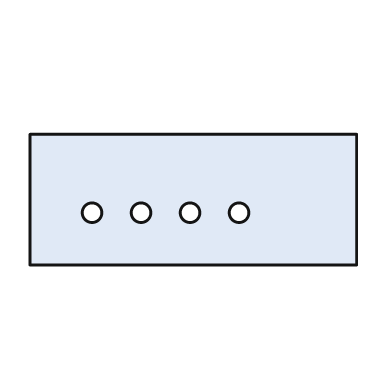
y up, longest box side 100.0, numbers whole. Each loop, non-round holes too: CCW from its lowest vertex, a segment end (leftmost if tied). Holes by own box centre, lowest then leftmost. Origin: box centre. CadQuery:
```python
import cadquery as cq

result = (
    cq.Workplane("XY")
    .moveTo(-50.0, -20.0)
    .lineTo(50.0, -20.0)
    .lineTo(50.0, 20.0)
    .lineTo(-50.0, 20.0)
    .close()
    .moveTo(-31.0, -4.0)
    .circle(3.0)
    .moveTo(-16.0, -4.0)
    .circle(3.0)
    .moveTo(-1.0, -4.0)
    .circle(3.0)
    .moveTo(14.0, -4.0)
    .circle(3.0)
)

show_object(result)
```